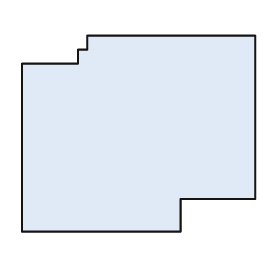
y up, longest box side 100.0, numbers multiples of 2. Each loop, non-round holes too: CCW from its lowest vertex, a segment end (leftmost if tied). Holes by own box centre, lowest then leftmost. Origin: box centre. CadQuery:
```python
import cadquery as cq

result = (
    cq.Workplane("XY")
    .moveTo(-50.0, -42.0)
    .lineTo(18.0, -42.0)
    .lineTo(18.0, -28.0)
    .lineTo(50.0, -28.0)
    .lineTo(50.0, 42.0)
    .lineTo(-22.0, 42.0)
    .lineTo(-22.0, 36.0)
    .lineTo(-26.0, 36.0)
    .lineTo(-26.0, 30.0)
    .lineTo(-50.0, 30.0)
    .close()
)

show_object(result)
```